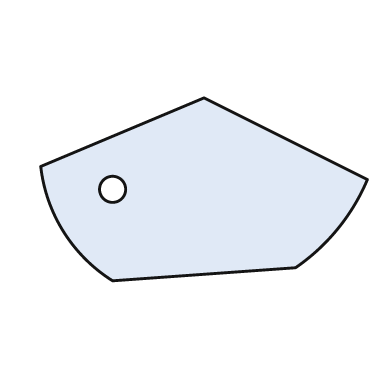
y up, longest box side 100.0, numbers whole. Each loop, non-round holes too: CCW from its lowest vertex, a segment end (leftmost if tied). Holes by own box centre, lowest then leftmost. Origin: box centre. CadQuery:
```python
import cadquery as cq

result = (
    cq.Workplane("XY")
    .moveTo(-28.0, -28.0)
    .lineTo(28.0, -24.0)
    .threePointArc((41.0, -12.0), (50.0, 3.0))
    .lineTo(0.0, 28.0)
    .lineTo(-50.0, 7.0)
    .threePointArc((-43.0, -13.0), (-28.0, -28.0))
    .close()
    .moveTo(-28.0, 0.0)
    .circle(4.0)
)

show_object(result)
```